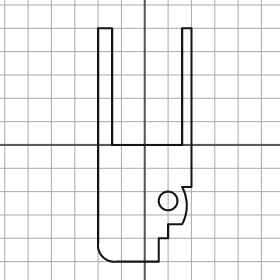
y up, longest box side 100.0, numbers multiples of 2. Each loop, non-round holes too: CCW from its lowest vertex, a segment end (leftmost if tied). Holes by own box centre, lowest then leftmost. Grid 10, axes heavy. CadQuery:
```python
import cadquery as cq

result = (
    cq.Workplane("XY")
    .moveTo(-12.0, -50.0)
    .lineTo(6.0, -50.0)
    .lineTo(6.0, -40.0)
    .lineTo(10.0, -40.0)
    .lineTo(10.0, -34.0)
    .lineTo(16.0, -34.0)
    .threePointArc((18.0, -26.0), (16.0, -18.0))
    .lineTo(20.0, -18.0)
    .lineTo(20.0, 50.0)
    .lineTo(16.0, 50.0)
    .lineTo(16.0, 0.0)
    .lineTo(-14.0, 0.0)
    .lineTo(-14.0, 50.0)
    .lineTo(-20.0, 50.0)
    .lineTo(-20.0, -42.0)
    .threePointArc((-18.0, -48.0), (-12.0, -50.0))
    .close()
    .moveTo(10.0, -24.0)
    .circle(4.0)
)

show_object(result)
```